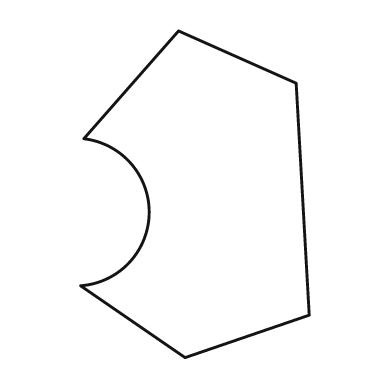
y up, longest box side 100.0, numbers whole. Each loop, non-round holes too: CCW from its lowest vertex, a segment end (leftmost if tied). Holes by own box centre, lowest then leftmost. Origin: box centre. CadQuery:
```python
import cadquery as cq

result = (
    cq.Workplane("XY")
    .moveTo(-3.0, -50.0)
    .lineTo(35.0, -37.0)
    .lineTo(31.0, 34.0)
    .lineTo(-5.0, 50.0)
    .lineTo(-34.0, 17.0)
    .threePointArc((-14.0, -6.0), (-35.0, -28.0))
    .close()
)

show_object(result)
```